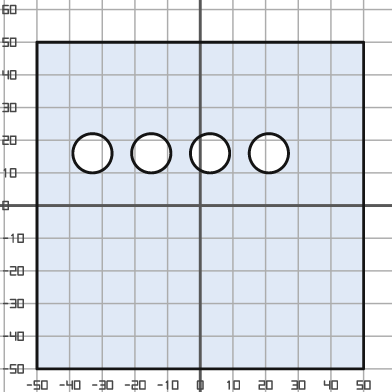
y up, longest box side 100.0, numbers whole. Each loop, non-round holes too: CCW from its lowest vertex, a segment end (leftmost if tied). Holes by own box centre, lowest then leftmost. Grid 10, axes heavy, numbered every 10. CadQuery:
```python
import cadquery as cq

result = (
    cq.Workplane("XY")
    .moveTo(-50.0, -50.0)
    .lineTo(50.0, -50.0)
    .lineTo(50.0, 50.0)
    .lineTo(-50.0, 50.0)
    .close()
    .moveTo(-33.0, 16.0)
    .circle(6.0)
    .moveTo(-15.0, 16.0)
    .circle(6.0)
    .moveTo(3.0, 16.0)
    .circle(6.0)
    .moveTo(21.0, 16.0)
    .circle(6.0)
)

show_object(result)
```